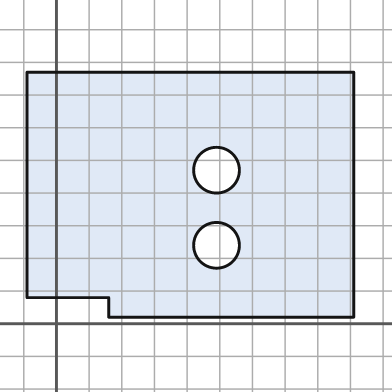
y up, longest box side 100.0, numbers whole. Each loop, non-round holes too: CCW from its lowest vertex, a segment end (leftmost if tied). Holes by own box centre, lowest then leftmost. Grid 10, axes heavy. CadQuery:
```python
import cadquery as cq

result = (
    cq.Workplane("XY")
    .moveTo(16.0, 2.0)
    .lineTo(91.0, 2.0)
    .lineTo(91.0, 77.0)
    .lineTo(-9.0, 77.0)
    .lineTo(-9.0, 8.0)
    .lineTo(16.0, 8.0)
    .close()
    .moveTo(49.0, 24.0)
    .circle(7.0)
    .moveTo(49.0, 47.0)
    .circle(7.0)
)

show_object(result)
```